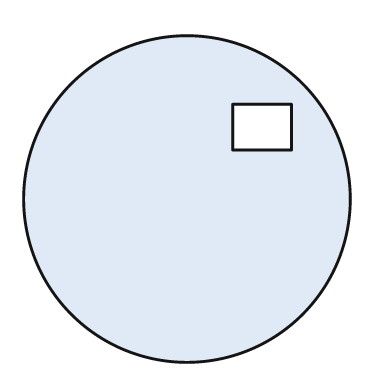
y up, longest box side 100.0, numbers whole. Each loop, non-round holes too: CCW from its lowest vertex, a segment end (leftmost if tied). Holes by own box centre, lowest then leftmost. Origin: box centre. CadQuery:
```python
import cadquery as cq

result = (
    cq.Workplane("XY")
    .moveTo(0.0, 0.0)
    .circle(50.0)
    .moveTo(14.0, 15.0)
    .lineTo(32.0, 15.0)
    .lineTo(32.0, 29.0)
    .lineTo(14.0, 29.0)
    .close()
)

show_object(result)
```